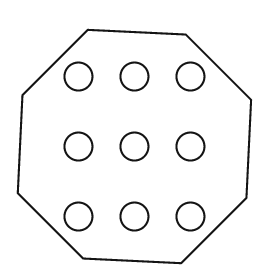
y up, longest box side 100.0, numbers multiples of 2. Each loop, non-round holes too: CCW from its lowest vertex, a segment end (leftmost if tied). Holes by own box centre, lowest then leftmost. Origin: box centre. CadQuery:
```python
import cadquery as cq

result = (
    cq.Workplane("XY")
    .moveTo(20.0, -50.0)
    .lineTo(48.0, -22.0)
    .lineTo(50.0, 20.0)
    .lineTo(22.0, 48.0)
    .lineTo(-20.0, 50.0)
    .lineTo(-48.0, 22.0)
    .lineTo(-50.0, -20.0)
    .lineTo(-22.0, -48.0)
    .close()
    .moveTo(-24.0, -30.0)
    .circle(6.0)
    .moveTo(0.0, -30.0)
    .circle(6.0)
    .moveTo(24.0, -30.0)
    .circle(6.0)
    .moveTo(-24.0, 0.0)
    .circle(6.0)
    .moveTo(0.0, 0.0)
    .circle(6.0)
    .moveTo(24.0, 0.0)
    .circle(6.0)
    .moveTo(-24.0, 30.0)
    .circle(6.0)
    .moveTo(0.0, 30.0)
    .circle(6.0)
    .moveTo(24.0, 30.0)
    .circle(6.0)
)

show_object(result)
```